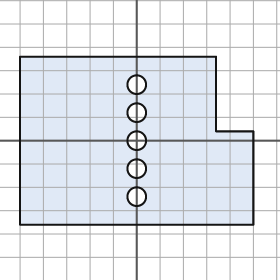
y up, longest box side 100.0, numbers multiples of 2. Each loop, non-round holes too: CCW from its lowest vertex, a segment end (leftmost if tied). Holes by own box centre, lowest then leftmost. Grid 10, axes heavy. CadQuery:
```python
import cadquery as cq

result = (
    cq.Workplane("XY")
    .moveTo(-50.0, -36.0)
    .lineTo(50.0, -36.0)
    .lineTo(50.0, 4.0)
    .lineTo(34.0, 4.0)
    .lineTo(34.0, 36.0)
    .lineTo(-50.0, 36.0)
    .close()
    .moveTo(0.0, -24.0)
    .circle(4.0)
    .moveTo(0.0, -12.0)
    .circle(4.0)
    .moveTo(0.0, 0.0)
    .circle(4.0)
    .moveTo(0.0, 12.0)
    .circle(4.0)
    .moveTo(0.0, 24.0)
    .circle(4.0)
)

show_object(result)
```